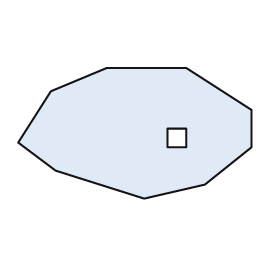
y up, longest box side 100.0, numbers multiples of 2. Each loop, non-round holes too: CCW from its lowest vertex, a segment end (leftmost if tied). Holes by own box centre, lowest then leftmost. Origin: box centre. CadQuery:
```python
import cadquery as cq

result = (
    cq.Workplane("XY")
    .moveTo(4.0, -28.0)
    .lineTo(30.0, -22.0)
    .lineTo(50.0, -6.0)
    .lineTo(50.0, 10.0)
    .lineTo(22.0, 28.0)
    .lineTo(-12.0, 28.0)
    .lineTo(-36.0, 18.0)
    .lineTo(-50.0, -4.0)
    .lineTo(-34.0, -16.0)
    .close()
    .moveTo(14.0, -6.0)
    .lineTo(22.0, -6.0)
    .lineTo(22.0, 2.0)
    .lineTo(14.0, 2.0)
    .close()
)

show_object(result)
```